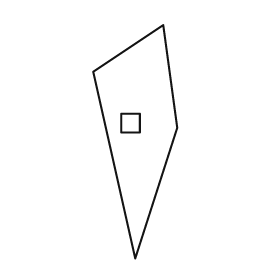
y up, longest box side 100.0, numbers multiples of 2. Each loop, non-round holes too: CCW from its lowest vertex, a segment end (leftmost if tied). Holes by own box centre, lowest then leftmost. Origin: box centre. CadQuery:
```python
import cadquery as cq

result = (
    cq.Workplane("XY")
    .moveTo(0.0, -50.0)
    .lineTo(18.0, 6.0)
    .lineTo(12.0, 50.0)
    .lineTo(-18.0, 30.0)
    .close()
    .moveTo(-6.0, 4.0)
    .lineTo(2.0, 4.0)
    .lineTo(2.0, 12.0)
    .lineTo(-6.0, 12.0)
    .close()
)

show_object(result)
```